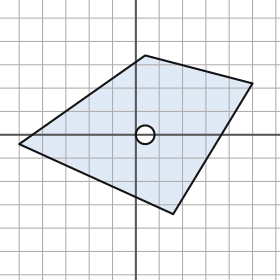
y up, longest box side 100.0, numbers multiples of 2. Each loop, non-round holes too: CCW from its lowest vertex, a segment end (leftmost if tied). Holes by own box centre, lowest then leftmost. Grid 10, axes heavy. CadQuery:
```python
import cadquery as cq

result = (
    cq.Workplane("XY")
    .moveTo(16.0, -34.0)
    .lineTo(50.0, 22.0)
    .lineTo(4.0, 34.0)
    .lineTo(-50.0, -4.0)
    .close()
    .moveTo(4.0, 0.0)
    .circle(4.0)
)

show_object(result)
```